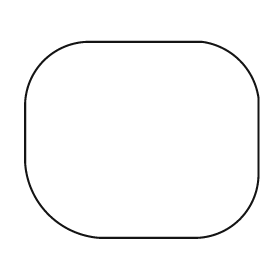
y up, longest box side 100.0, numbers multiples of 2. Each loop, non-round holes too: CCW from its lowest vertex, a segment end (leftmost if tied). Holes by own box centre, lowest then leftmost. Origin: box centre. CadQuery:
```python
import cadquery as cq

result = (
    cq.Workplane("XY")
    .moveTo(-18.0, -42.0)
    .lineTo(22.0, -42.0)
    .threePointArc((42.0, -34.0), (50.0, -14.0))
    .lineTo(50.0, 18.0)
    .threePointArc((42.0, 34.0), (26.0, 42.0))
    .lineTo(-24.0, 42.0)
    .threePointArc((-42.0, 34.0), (-50.0, 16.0))
    .lineTo(-50.0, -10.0)
    .threePointArc((-40.0, -32.0), (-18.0, -42.0))
    .close()
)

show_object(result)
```